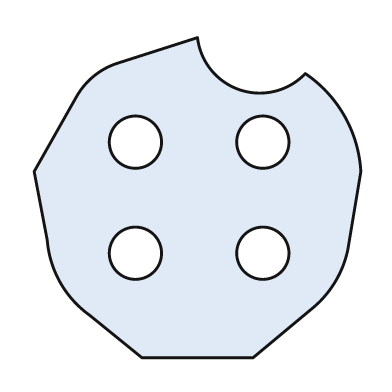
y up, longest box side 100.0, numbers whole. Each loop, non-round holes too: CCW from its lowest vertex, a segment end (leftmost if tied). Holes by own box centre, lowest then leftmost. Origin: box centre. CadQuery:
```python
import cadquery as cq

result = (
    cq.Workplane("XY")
    .moveTo(-17.0, -49.0)
    .lineTo(17.0, -49.0)
    .lineTo(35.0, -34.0)
    .threePointArc((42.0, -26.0), (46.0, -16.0))
    .lineTo(50.0, 8.0)
    .threePointArc((45.0, 25.0), (33.0, 38.0))
    .threePointArc((13.0, 33.0), (0.0, 49.0))
    .lineTo(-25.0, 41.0)
    .threePointArc((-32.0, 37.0), (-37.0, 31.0))
    .lineTo(-50.0, 8.0)
    .lineTo(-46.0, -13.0)
    .threePointArc((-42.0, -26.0), (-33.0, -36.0))
    .close()
    .moveTo(-19.0, -17.0)
    .circle(8.0)
    .moveTo(20.0, -17.0)
    .circle(8.0)
    .moveTo(-19.0, 17.0)
    .circle(8.0)
    .moveTo(20.0, 17.0)
    .circle(8.0)
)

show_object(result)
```